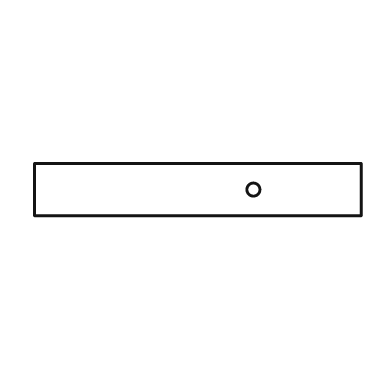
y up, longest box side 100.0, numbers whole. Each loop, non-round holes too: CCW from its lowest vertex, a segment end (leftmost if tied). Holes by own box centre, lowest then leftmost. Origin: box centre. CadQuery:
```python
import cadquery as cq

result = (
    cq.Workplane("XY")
    .moveTo(-50.0, -8.0)
    .lineTo(50.0, -8.0)
    .lineTo(50.0, 8.0)
    .lineTo(-50.0, 8.0)
    .close()
    .moveTo(17.0, 0.0)
    .circle(2.0)
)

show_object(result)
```